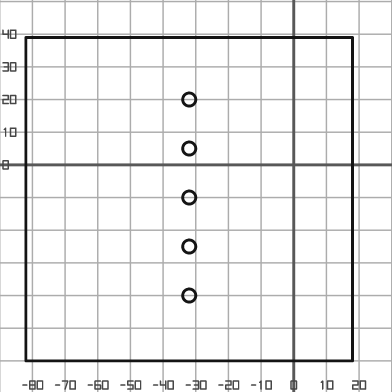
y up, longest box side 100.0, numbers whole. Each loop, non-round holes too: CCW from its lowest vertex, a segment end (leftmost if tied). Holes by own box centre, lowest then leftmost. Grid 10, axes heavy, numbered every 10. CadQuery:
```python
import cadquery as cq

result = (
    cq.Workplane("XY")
    .moveTo(-82.0, -60.0)
    .lineTo(18.0, -60.0)
    .lineTo(18.0, 39.0)
    .lineTo(-82.0, 39.0)
    .close()
    .moveTo(-32.0, -40.0)
    .circle(2.0)
    .moveTo(-32.0, -25.0)
    .circle(2.0)
    .moveTo(-32.0, -10.0)
    .circle(2.0)
    .moveTo(-32.0, 5.0)
    .circle(2.0)
    .moveTo(-32.0, 20.0)
    .circle(2.0)
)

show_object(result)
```